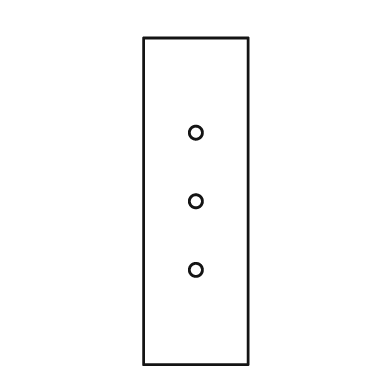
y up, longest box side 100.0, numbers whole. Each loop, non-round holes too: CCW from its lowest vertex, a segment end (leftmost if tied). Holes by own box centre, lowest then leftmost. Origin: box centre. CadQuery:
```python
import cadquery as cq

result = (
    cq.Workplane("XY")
    .moveTo(-16.0, -50.0)
    .lineTo(16.0, -50.0)
    .lineTo(16.0, 50.0)
    .lineTo(-16.0, 50.0)
    .close()
    .moveTo(0.0, -21.0)
    .circle(2.0)
    .moveTo(0.0, 0.0)
    .circle(2.0)
    .moveTo(0.0, 21.0)
    .circle(2.0)
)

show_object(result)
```